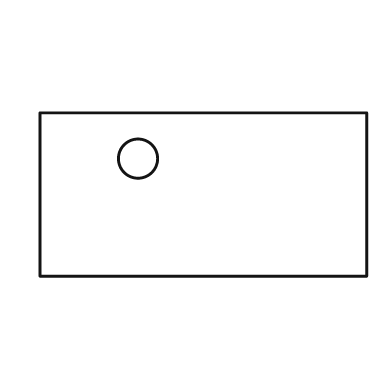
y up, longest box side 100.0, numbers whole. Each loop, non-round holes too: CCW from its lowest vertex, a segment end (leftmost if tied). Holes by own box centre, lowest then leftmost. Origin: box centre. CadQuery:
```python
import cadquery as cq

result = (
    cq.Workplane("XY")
    .moveTo(-50.0, -25.0)
    .lineTo(50.0, -25.0)
    .lineTo(50.0, 25.0)
    .lineTo(-50.0, 25.0)
    .close()
    .moveTo(-20.0, 11.0)
    .circle(6.0)
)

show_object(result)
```